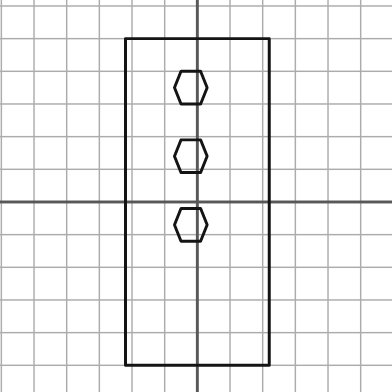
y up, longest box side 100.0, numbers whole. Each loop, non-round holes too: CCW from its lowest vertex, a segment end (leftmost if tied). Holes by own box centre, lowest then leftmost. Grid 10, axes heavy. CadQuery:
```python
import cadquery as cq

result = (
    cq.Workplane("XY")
    .moveTo(-22.0, -50.0)
    .lineTo(22.0, -50.0)
    .lineTo(22.0, 50.0)
    .lineTo(-22.0, 50.0)
    .close()
    .moveTo(-5.0, -12.0)
    .lineTo(1.0, -12.0)
    .lineTo(3.0, -7.0)
    .lineTo(1.0, -2.0)
    .lineTo(-5.0, -2.0)
    .lineTo(-7.0, -7.0)
    .close()
    .moveTo(-5.0, 9.0)
    .lineTo(1.0, 9.0)
    .lineTo(3.0, 14.0)
    .lineTo(1.0, 19.0)
    .lineTo(-5.0, 19.0)
    .lineTo(-7.0, 14.0)
    .close()
    .moveTo(-5.0, 30.0)
    .lineTo(1.0, 30.0)
    .lineTo(3.0, 35.0)
    .lineTo(1.0, 40.0)
    .lineTo(-5.0, 40.0)
    .lineTo(-7.0, 35.0)
    .close()
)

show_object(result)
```